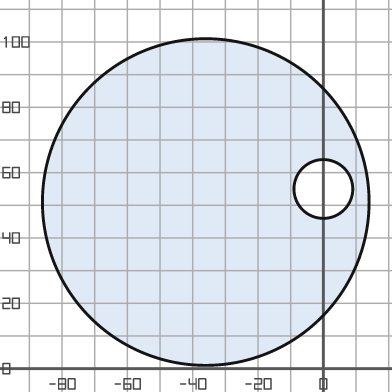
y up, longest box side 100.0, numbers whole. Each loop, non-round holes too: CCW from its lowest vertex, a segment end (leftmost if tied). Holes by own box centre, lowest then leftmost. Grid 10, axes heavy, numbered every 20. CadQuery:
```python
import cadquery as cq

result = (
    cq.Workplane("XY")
    .moveTo(-36.0, 51.0)
    .circle(50.0)
    .moveTo(0.0, 55.0)
    .circle(9.0)
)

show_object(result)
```